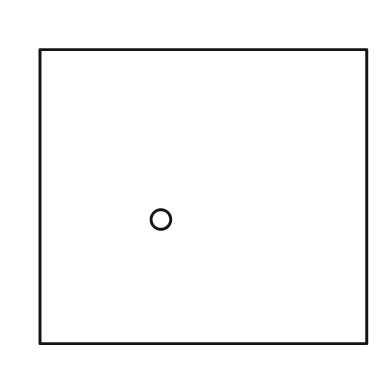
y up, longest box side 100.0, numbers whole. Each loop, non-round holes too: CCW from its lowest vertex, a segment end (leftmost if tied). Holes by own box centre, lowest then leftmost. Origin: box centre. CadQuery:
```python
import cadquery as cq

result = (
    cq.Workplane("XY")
    .moveTo(-50.0, -45.0)
    .lineTo(50.0, -45.0)
    .lineTo(50.0, 45.0)
    .lineTo(-50.0, 45.0)
    .close()
    .moveTo(-13.0, -7.0)
    .circle(3.0)
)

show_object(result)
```